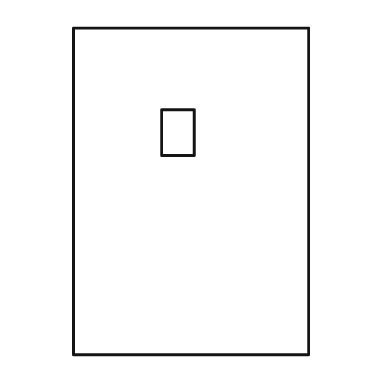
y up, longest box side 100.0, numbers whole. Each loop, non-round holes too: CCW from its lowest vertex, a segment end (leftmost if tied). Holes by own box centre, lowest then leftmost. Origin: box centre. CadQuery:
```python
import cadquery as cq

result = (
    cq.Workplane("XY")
    .moveTo(-36.0, -50.0)
    .lineTo(36.0, -50.0)
    .lineTo(36.0, 50.0)
    .lineTo(-36.0, 50.0)
    .close()
    .moveTo(-9.0, 11.0)
    .lineTo(1.0, 11.0)
    .lineTo(1.0, 25.0)
    .lineTo(-9.0, 25.0)
    .close()
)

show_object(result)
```